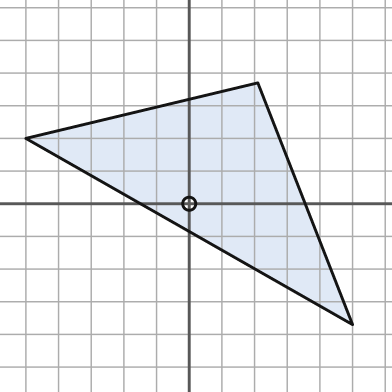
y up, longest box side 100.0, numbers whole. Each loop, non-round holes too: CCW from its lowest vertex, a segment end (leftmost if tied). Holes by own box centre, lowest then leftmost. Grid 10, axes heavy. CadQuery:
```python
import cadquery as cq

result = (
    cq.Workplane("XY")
    .moveTo(50.0, -37.0)
    .lineTo(21.0, 37.0)
    .lineTo(-50.0, 20.0)
    .close()
    .moveTo(0.0, 0.0)
    .circle(2.0)
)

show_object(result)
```